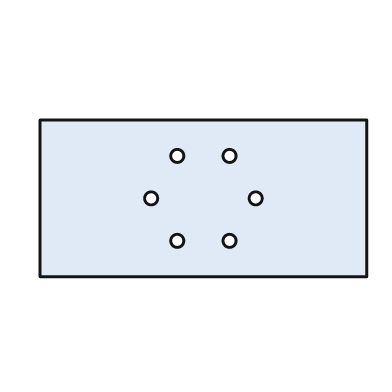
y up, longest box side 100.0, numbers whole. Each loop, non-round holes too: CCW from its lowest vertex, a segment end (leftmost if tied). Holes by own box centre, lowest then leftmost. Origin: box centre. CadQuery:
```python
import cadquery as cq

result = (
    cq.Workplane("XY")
    .moveTo(-50.0, -24.0)
    .lineTo(50.0, -24.0)
    .lineTo(50.0, 24.0)
    .lineTo(-50.0, 24.0)
    .close()
    .moveTo(-8.0, -13.0)
    .circle(2.0)
    .moveTo(8.0, -13.0)
    .circle(2.0)
    .moveTo(-16.0, 0.0)
    .circle(2.0)
    .moveTo(16.0, 0.0)
    .circle(2.0)
    .moveTo(-8.0, 13.0)
    .circle(2.0)
    .moveTo(8.0, 13.0)
    .circle(2.0)
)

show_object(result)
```